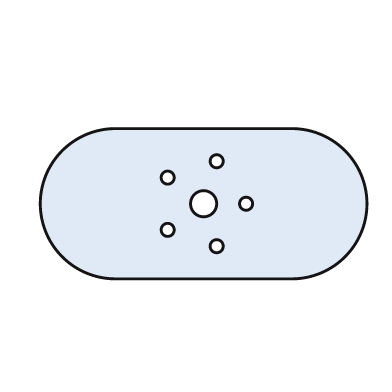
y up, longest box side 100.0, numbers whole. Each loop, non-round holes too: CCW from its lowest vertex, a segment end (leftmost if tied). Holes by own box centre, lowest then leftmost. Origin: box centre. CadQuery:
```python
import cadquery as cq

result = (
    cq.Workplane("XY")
    .moveTo(-27.0, -23.0)
    .lineTo(27.0, -23.0)
    .threePointArc((50.0, 0.0), (27.0, 23.0))
    .lineTo(-27.0, 23.0)
    .threePointArc((-50.0, 0.0), (-27.0, -23.0))
    .close()
    .moveTo(4.0, -13.0)
    .circle(2.0)
    .moveTo(-11.0, -8.0)
    .circle(2.0)
    .moveTo(0.0, 0.0)
    .circle(4.0)
    .moveTo(13.0, 0.0)
    .circle(2.0)
    .moveTo(-11.0, 8.0)
    .circle(2.0)
    .moveTo(4.0, 13.0)
    .circle(2.0)
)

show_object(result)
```